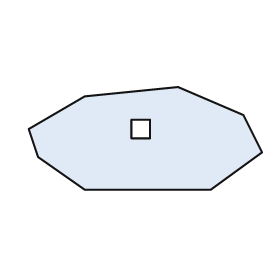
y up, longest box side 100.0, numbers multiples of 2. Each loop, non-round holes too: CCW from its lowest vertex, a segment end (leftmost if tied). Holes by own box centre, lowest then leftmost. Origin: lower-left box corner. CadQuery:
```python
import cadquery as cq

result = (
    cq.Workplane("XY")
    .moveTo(24.0, 0.0)
    .lineTo(78.0, 0.0)
    .lineTo(100.0, 16.0)
    .lineTo(92.0, 32.0)
    .lineTo(64.0, 44.0)
    .lineTo(24.0, 40.0)
    .lineTo(0.0, 26.0)
    .lineTo(4.0, 14.0)
    .close()
    .moveTo(44.0, 22.0)
    .lineTo(52.0, 22.0)
    .lineTo(52.0, 30.0)
    .lineTo(44.0, 30.0)
    .close()
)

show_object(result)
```